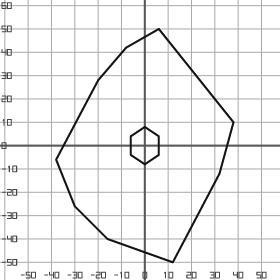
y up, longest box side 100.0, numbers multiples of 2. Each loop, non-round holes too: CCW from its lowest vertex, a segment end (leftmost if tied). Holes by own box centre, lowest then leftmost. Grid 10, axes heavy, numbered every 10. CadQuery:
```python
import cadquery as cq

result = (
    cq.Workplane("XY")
    .moveTo(12.0, -50.0)
    .lineTo(32.0, -12.0)
    .lineTo(38.0, 10.0)
    .lineTo(6.0, 50.0)
    .lineTo(-8.0, 42.0)
    .lineTo(-20.0, 28.0)
    .lineTo(-38.0, -6.0)
    .lineTo(-30.0, -26.0)
    .lineTo(-16.0, -40.0)
    .close()
    .moveTo(0.0, -8.0)
    .lineTo(6.0, -4.0)
    .lineTo(6.0, 4.0)
    .lineTo(0.0, 8.0)
    .lineTo(-6.0, 4.0)
    .lineTo(-6.0, -4.0)
    .close()
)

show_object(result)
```